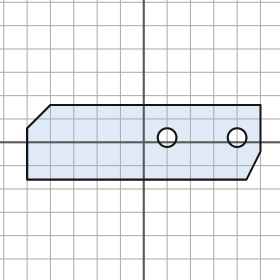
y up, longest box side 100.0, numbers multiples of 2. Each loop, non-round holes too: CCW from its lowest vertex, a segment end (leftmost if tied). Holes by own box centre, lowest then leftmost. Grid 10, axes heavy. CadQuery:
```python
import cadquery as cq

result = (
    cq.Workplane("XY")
    .moveTo(-50.0, -16.0)
    .lineTo(44.0, -16.0)
    .lineTo(50.0, -4.0)
    .lineTo(50.0, 16.0)
    .lineTo(-40.0, 16.0)
    .lineTo(-50.0, 6.0)
    .close()
    .moveTo(10.0, 2.0)
    .circle(4.0)
    .moveTo(40.0, 2.0)
    .circle(4.0)
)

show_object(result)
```